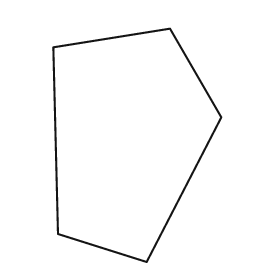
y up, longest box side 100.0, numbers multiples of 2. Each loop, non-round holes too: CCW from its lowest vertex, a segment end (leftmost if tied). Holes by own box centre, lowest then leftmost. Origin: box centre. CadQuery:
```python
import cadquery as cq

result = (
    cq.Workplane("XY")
    .moveTo(4.0, -50.0)
    .lineTo(36.0, 12.0)
    .lineTo(14.0, 50.0)
    .lineTo(-36.0, 42.0)
    .lineTo(-34.0, -38.0)
    .close()
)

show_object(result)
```